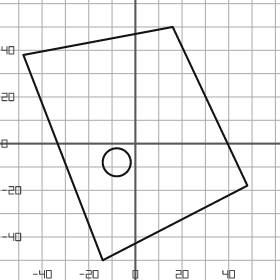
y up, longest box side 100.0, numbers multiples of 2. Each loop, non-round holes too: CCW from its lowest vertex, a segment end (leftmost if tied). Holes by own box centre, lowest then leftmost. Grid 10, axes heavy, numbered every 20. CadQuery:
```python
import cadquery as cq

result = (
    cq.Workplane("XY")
    .moveTo(-14.0, -50.0)
    .lineTo(48.0, -18.0)
    .lineTo(16.0, 50.0)
    .lineTo(-48.0, 38.0)
    .close()
    .moveTo(-8.0, -8.0)
    .circle(6.0)
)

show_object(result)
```